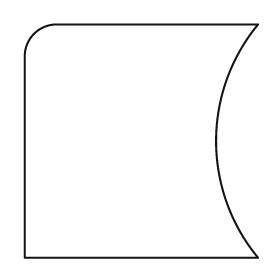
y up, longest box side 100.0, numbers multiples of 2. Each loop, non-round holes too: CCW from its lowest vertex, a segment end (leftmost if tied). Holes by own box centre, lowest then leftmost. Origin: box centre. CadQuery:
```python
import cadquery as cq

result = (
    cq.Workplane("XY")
    .moveTo(-50.0, -50.0)
    .lineTo(50.0, -50.0)
    .threePointArc((32.0, 0.0), (50.0, 50.0))
    .lineTo(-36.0, 50.0)
    .threePointArc((-46.0, 46.0), (-50.0, 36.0))
    .close()
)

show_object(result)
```